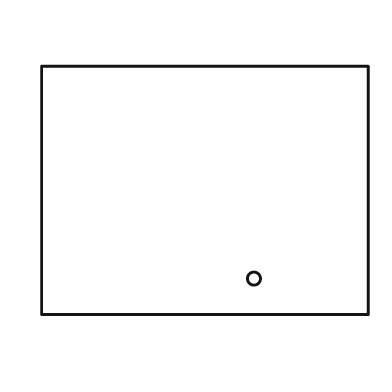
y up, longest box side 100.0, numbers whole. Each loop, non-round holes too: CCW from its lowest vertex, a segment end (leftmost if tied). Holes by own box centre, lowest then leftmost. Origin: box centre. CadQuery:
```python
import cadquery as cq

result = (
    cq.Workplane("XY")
    .moveTo(-50.0, -38.0)
    .lineTo(50.0, -38.0)
    .lineTo(50.0, 38.0)
    .lineTo(-50.0, 38.0)
    .close()
    .moveTo(15.0, -27.0)
    .circle(2.0)
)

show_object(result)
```